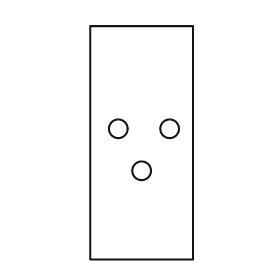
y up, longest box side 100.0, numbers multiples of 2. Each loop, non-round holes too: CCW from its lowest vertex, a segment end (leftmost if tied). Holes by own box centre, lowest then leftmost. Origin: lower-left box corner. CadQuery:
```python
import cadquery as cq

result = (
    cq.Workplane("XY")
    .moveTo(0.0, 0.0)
    .lineTo(44.0, 0.0)
    .lineTo(44.0, 100.0)
    .lineTo(0.0, 100.0)
    .close()
    .moveTo(22.0, 38.0)
    .circle(4.0)
    .moveTo(12.0, 56.0)
    .circle(4.0)
    .moveTo(34.0, 56.0)
    .circle(4.0)
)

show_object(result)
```